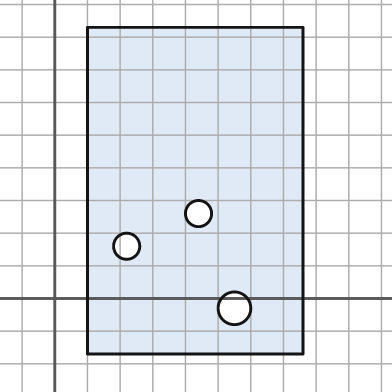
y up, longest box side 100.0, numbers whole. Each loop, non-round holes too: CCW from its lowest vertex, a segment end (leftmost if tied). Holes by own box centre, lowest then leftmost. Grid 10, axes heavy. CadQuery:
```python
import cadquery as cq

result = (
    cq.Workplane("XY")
    .moveTo(10.0, -17.0)
    .lineTo(76.0, -17.0)
    .lineTo(76.0, 83.0)
    .lineTo(10.0, 83.0)
    .close()
    .moveTo(55.0, -3.0)
    .circle(5.0)
    .moveTo(22.0, 16.0)
    .circle(4.0)
    .moveTo(44.0, 26.0)
    .circle(4.0)
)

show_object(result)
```